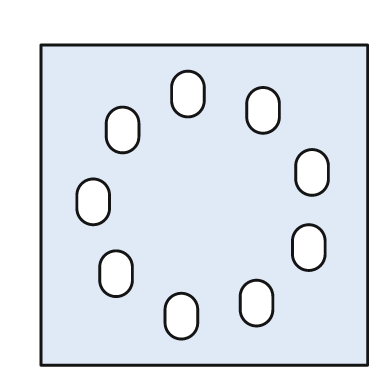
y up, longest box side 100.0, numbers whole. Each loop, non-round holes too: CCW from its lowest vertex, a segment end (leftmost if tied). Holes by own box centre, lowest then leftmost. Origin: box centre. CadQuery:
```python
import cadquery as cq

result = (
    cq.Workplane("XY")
    .moveTo(-50.0, -49.0)
    .lineTo(50.0, -49.0)
    .lineTo(50.0, 49.0)
    .lineTo(-50.0, 49.0)
    .close()
    .moveTo(-12.0, -36.0)
    .threePointArc((-7.0, -41.0), (-2.0, -36.0))
    .lineTo(-2.0, -32.0)
    .threePointArc((-7.0, -27.0), (-12.0, -32.0))
    .close()
    .moveTo(11.0, -32.0)
    .threePointArc((16.0, -37.0), (21.0, -32.0))
    .lineTo(21.0, -28.0)
    .threePointArc((16.0, -23.0), (11.0, -28.0))
    .close()
    .moveTo(-32.0, -23.0)
    .threePointArc((-27.0, -28.0), (-22.0, -23.0))
    .lineTo(-22.0, -19.0)
    .threePointArc((-27.0, -14.0), (-32.0, -19.0))
    .close()
    .moveTo(27.0, -15.0)
    .threePointArc((32.0, -20.0), (37.0, -15.0))
    .lineTo(37.0, -11.0)
    .threePointArc((32.0, -6.0), (27.0, -11.0))
    .close()
    .moveTo(-39.0, -1.0)
    .threePointArc((-34.0, -6.0), (-29.0, -1.0))
    .lineTo(-29.0, 3.0)
    .threePointArc((-34.0, 8.0), (-39.0, 3.0))
    .close()
    .moveTo(28.0, 8.0)
    .threePointArc((33.0, 3.0), (38.0, 8.0))
    .lineTo(38.0, 12.0)
    .threePointArc((33.0, 17.0), (28.0, 12.0))
    .close()
    .moveTo(-30.0, 21.0)
    .threePointArc((-25.0, 16.0), (-20.0, 21.0))
    .lineTo(-20.0, 25.0)
    .threePointArc((-25.0, 30.0), (-30.0, 25.0))
    .close()
    .moveTo(13.0, 27.0)
    .threePointArc((18.0, 22.0), (23.0, 27.0))
    .lineTo(23.0, 31.0)
    .threePointArc((18.0, 36.0), (13.0, 31.0))
    .close()
    .moveTo(-10.0, 32.0)
    .threePointArc((-5.0, 27.0), (0.0, 32.0))
    .lineTo(0.0, 36.0)
    .threePointArc((-5.0, 41.0), (-10.0, 36.0))
    .close()
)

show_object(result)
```